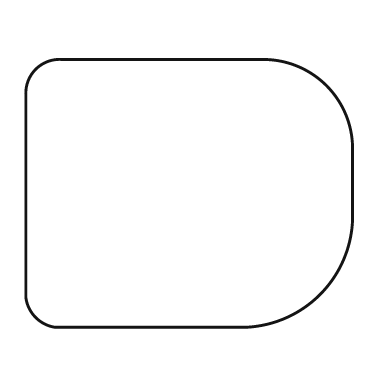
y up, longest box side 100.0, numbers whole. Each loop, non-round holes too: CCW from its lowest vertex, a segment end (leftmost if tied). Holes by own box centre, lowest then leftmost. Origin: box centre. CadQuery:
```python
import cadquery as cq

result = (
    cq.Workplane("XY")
    .moveTo(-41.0, -41.0)
    .lineTo(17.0, -41.0)
    .threePointArc((40.0, -31.0), (50.0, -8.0))
    .lineTo(50.0, 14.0)
    .threePointArc((42.0, 33.0), (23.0, 41.0))
    .lineTo(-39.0, 41.0)
    .threePointArc((-47.0, 38.0), (-50.0, 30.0))
    .lineTo(-50.0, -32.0)
    .threePointArc((-47.0, -38.0), (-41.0, -41.0))
    .close()
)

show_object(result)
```